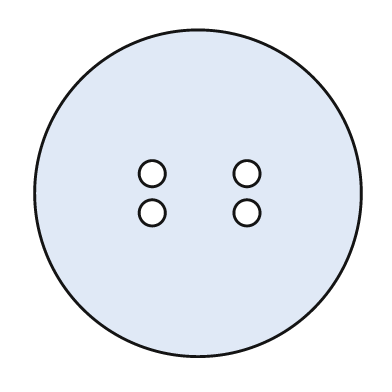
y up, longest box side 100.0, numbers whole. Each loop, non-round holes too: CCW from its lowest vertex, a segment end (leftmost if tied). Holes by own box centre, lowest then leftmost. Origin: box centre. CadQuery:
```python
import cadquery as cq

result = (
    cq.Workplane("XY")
    .moveTo(0.0, 0.0)
    .circle(50.0)
    .moveTo(-14.0, -6.0)
    .circle(4.0)
    .moveTo(15.0, -6.0)
    .circle(4.0)
    .moveTo(-14.0, 6.0)
    .circle(4.0)
    .moveTo(15.0, 6.0)
    .circle(4.0)
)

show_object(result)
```